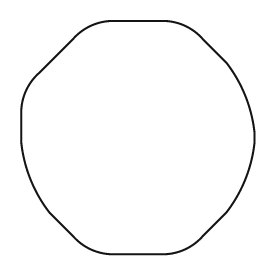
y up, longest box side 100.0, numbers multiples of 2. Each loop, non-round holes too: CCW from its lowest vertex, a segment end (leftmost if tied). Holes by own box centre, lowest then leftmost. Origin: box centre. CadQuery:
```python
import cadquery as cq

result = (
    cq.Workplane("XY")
    .moveTo(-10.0, -50.0)
    .lineTo(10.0, -50.0)
    .threePointArc((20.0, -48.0), (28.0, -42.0))
    .lineTo(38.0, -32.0)
    .threePointArc((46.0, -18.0), (50.0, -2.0))
    .lineTo(50.0, 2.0)
    .threePointArc((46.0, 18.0), (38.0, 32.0))
    .lineTo(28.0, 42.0)
    .threePointArc((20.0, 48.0), (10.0, 50.0))
    .lineTo(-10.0, 50.0)
    .threePointArc((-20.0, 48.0), (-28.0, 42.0))
    .lineTo(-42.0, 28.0)
    .threePointArc((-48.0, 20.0), (-50.0, 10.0))
    .lineTo(-50.0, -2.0)
    .threePointArc((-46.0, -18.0), (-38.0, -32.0))
    .lineTo(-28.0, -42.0)
    .threePointArc((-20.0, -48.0), (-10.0, -50.0))
    .close()
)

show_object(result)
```